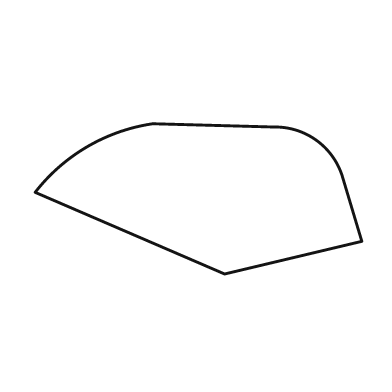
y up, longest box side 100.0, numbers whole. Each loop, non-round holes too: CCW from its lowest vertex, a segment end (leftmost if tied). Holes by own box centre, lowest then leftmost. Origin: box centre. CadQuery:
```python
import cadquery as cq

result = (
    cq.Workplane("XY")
    .moveTo(8.0, -23.0)
    .lineTo(50.0, -13.0)
    .lineTo(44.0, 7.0)
    .threePointArc((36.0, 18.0), (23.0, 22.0))
    .lineTo(-14.0, 23.0)
    .threePointArc((-34.0, 16.0), (-50.0, 2.0))
    .close()
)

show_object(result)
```